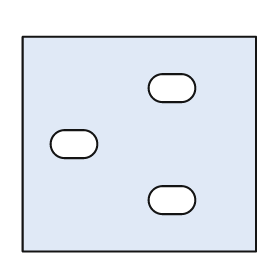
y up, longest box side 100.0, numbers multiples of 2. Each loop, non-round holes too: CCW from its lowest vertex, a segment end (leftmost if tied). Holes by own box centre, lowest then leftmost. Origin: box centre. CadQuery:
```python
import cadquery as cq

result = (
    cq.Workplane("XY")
    .moveTo(-50.0, -46.0)
    .lineTo(50.0, -46.0)
    .lineTo(50.0, 46.0)
    .lineTo(-50.0, 46.0)
    .close()
    .moveTo(10.0, -30.0)
    .lineTo(18.0, -30.0)
    .threePointArc((24.0, -24.0), (18.0, -18.0))
    .lineTo(10.0, -18.0)
    .threePointArc((4.0, -24.0), (10.0, -30.0))
    .close()
    .moveTo(-32.0, -6.0)
    .lineTo(-24.0, -6.0)
    .threePointArc((-18.0, 0.0), (-24.0, 6.0))
    .lineTo(-32.0, 6.0)
    .threePointArc((-38.0, 0.0), (-32.0, -6.0))
    .close()
    .moveTo(10.0, 18.0)
    .lineTo(18.0, 18.0)
    .threePointArc((24.0, 24.0), (18.0, 30.0))
    .lineTo(10.0, 30.0)
    .threePointArc((4.0, 24.0), (10.0, 18.0))
    .close()
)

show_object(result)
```